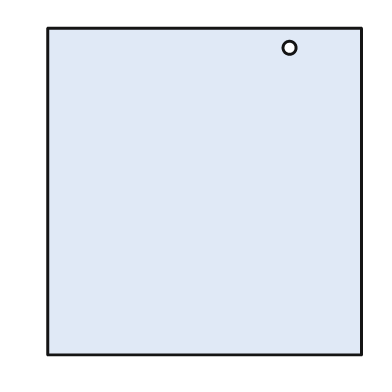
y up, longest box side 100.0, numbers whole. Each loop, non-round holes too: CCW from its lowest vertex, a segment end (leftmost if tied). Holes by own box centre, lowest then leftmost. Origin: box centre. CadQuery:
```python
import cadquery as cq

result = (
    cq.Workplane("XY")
    .moveTo(-48.0, -50.0)
    .lineTo(48.0, -50.0)
    .lineTo(48.0, 50.0)
    .lineTo(-48.0, 50.0)
    .close()
    .moveTo(26.0, 44.0)
    .circle(2.0)
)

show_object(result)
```